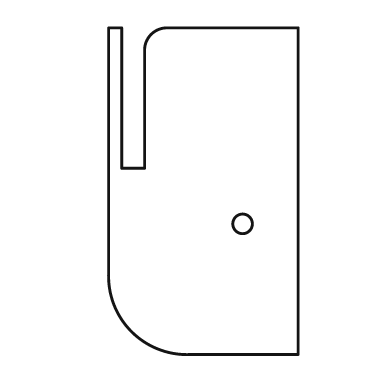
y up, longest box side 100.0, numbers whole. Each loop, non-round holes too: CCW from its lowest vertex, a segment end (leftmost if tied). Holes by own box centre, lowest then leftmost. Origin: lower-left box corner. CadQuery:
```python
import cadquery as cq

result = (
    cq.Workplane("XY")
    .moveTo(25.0, 0.0)
    .lineTo(58.0, 0.0)
    .lineTo(58.0, 100.0)
    .lineTo(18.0, 100.0)
    .threePointArc((13.0, 98.0), (11.0, 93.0))
    .lineTo(11.0, 57.0)
    .lineTo(4.0, 57.0)
    .lineTo(4.0, 100.0)
    .lineTo(0.0, 100.0)
    .lineTo(0.0, 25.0)
    .threePointArc((7.0, 7.0), (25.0, 0.0))
    .close()
    .moveTo(41.0, 40.0)
    .circle(3.0)
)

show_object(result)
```